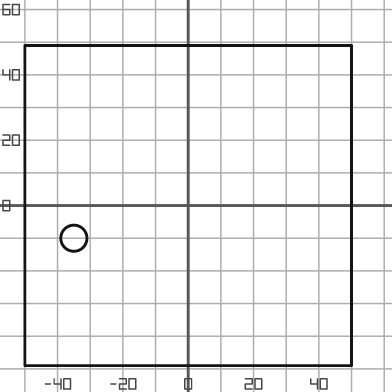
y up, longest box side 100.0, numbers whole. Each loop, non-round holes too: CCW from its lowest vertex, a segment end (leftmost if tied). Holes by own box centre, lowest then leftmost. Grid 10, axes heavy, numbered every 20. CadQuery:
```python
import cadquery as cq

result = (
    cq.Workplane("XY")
    .moveTo(-50.0, -49.0)
    .lineTo(50.0, -49.0)
    .lineTo(50.0, 49.0)
    .lineTo(-50.0, 49.0)
    .close()
    .moveTo(-35.0, -10.0)
    .circle(4.0)
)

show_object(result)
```